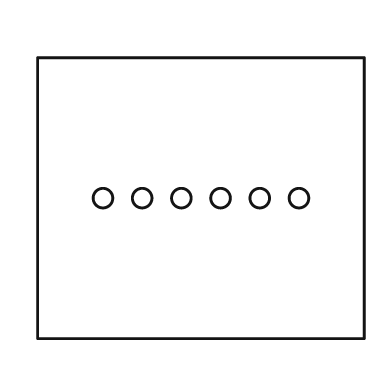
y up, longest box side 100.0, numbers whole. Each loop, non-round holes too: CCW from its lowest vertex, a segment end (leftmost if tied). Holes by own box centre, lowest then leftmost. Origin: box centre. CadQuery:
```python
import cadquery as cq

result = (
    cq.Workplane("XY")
    .moveTo(-50.0, -43.0)
    .lineTo(50.0, -43.0)
    .lineTo(50.0, 43.0)
    .lineTo(-50.0, 43.0)
    .close()
    .moveTo(-30.0, 0.0)
    .circle(3.0)
    .moveTo(-18.0, 0.0)
    .circle(3.0)
    .moveTo(-6.0, 0.0)
    .circle(3.0)
    .moveTo(6.0, 0.0)
    .circle(3.0)
    .moveTo(18.0, 0.0)
    .circle(3.0)
    .moveTo(30.0, 0.0)
    .circle(3.0)
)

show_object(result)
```